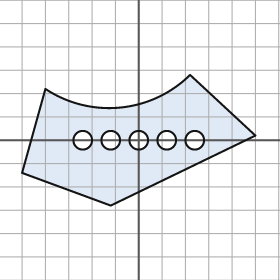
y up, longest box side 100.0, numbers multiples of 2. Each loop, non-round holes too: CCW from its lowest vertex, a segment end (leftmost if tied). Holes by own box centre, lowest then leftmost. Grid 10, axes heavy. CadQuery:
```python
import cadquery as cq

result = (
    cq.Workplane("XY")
    .moveTo(-12.0, -28.0)
    .lineTo(50.0, 2.0)
    .lineTo(22.0, 28.0)
    .threePointArc((-8.0, 14.0), (-40.0, 22.0))
    .lineTo(-50.0, -14.0)
    .close()
    .moveTo(-24.0, 0.0)
    .circle(4.0)
    .moveTo(-12.0, 0.0)
    .circle(4.0)
    .moveTo(0.0, 0.0)
    .circle(4.0)
    .moveTo(12.0, 0.0)
    .circle(4.0)
    .moveTo(24.0, 0.0)
    .circle(4.0)
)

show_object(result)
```